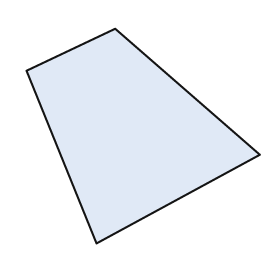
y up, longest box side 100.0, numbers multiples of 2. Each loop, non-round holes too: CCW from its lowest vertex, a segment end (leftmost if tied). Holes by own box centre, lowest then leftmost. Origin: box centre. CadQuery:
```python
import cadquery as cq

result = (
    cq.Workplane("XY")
    .moveTo(-20.0, -46.0)
    .lineTo(50.0, -8.0)
    .lineTo(-12.0, 46.0)
    .lineTo(-50.0, 28.0)
    .close()
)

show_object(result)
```